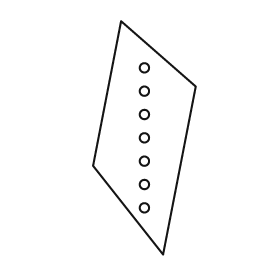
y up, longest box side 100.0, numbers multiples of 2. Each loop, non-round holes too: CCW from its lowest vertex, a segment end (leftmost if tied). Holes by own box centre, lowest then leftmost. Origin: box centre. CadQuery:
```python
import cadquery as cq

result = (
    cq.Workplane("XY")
    .moveTo(8.0, -50.0)
    .lineTo(22.0, 22.0)
    .lineTo(-10.0, 50.0)
    .lineTo(-22.0, -12.0)
    .close()
    .moveTo(0.0, -30.0)
    .circle(2.0)
    .moveTo(0.0, -20.0)
    .circle(2.0)
    .moveTo(0.0, -10.0)
    .circle(2.0)
    .moveTo(0.0, 0.0)
    .circle(2.0)
    .moveTo(0.0, 10.0)
    .circle(2.0)
    .moveTo(0.0, 20.0)
    .circle(2.0)
    .moveTo(0.0, 30.0)
    .circle(2.0)
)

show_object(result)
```